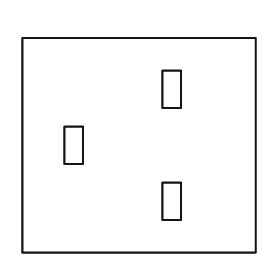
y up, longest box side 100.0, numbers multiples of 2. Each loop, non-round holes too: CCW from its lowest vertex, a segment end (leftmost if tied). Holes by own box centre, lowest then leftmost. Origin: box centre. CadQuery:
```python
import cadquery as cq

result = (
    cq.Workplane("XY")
    .moveTo(-50.0, -46.0)
    .lineTo(50.0, -46.0)
    .lineTo(50.0, 46.0)
    .lineTo(-50.0, 46.0)
    .close()
    .moveTo(10.0, -32.0)
    .lineTo(18.0, -32.0)
    .lineTo(18.0, -16.0)
    .lineTo(10.0, -16.0)
    .close()
    .moveTo(-32.0, -8.0)
    .lineTo(-24.0, -8.0)
    .lineTo(-24.0, 8.0)
    .lineTo(-32.0, 8.0)
    .close()
    .moveTo(10.0, 16.0)
    .lineTo(18.0, 16.0)
    .lineTo(18.0, 32.0)
    .lineTo(10.0, 32.0)
    .close()
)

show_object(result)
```